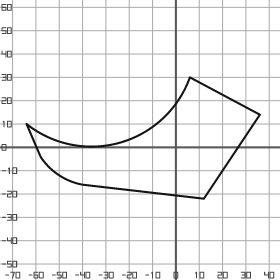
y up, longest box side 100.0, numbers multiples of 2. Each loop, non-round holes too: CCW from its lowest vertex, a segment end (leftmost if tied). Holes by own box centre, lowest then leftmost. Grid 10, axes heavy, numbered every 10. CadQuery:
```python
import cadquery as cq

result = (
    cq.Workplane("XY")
    .moveTo(12.0, -22.0)
    .lineTo(36.0, 14.0)
    .lineTo(6.0, 30.0)
    .threePointArc((-24.0, 2.0), (-64.0, 10.0))
    .lineTo(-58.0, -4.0)
    .threePointArc((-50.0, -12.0), (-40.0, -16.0))
    .close()
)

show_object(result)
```